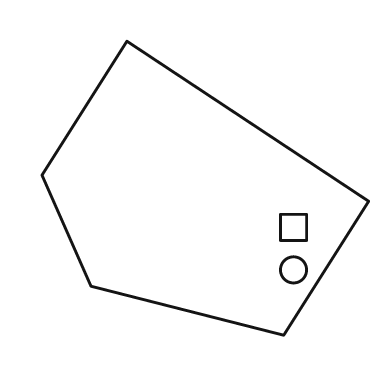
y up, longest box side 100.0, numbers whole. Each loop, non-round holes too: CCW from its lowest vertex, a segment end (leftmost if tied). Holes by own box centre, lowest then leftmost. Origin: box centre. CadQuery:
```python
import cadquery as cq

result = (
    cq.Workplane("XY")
    .moveTo(24.0, -45.0)
    .lineTo(50.0, -4.0)
    .lineTo(-24.0, 45.0)
    .lineTo(-50.0, 4.0)
    .lineTo(-35.0, -30.0)
    .close()
    .moveTo(27.0, -25.0)
    .circle(4.0)
    .moveTo(23.0, -16.0)
    .lineTo(31.0, -16.0)
    .lineTo(31.0, -8.0)
    .lineTo(23.0, -8.0)
    .close()
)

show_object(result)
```